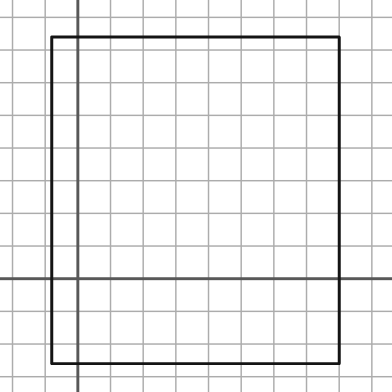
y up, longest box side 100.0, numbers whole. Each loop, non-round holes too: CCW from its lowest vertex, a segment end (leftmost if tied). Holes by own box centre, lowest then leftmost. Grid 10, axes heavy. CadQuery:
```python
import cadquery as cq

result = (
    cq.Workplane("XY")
    .moveTo(-8.0, -26.0)
    .lineTo(80.0, -26.0)
    .lineTo(80.0, 74.0)
    .lineTo(-8.0, 74.0)
    .close()
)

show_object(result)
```